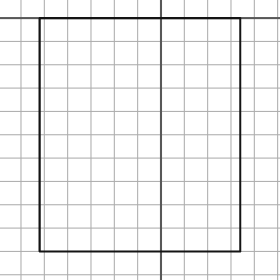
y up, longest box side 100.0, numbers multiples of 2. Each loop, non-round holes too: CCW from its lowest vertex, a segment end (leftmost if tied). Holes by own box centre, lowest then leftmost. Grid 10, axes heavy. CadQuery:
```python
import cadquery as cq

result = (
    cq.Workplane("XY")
    .moveTo(-52.0, -100.0)
    .lineTo(34.0, -100.0)
    .lineTo(34.0, 0.0)
    .lineTo(-52.0, 0.0)
    .close()
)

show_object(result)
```